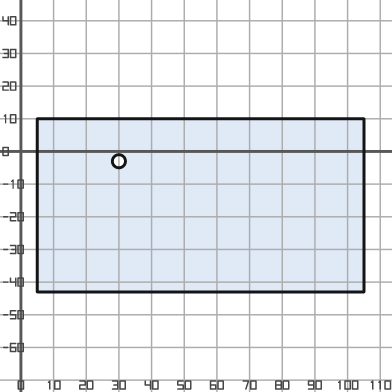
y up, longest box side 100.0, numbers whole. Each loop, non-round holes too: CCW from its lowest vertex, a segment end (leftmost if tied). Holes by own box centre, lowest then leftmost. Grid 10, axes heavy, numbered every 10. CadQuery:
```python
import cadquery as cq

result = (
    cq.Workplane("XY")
    .moveTo(5.0, -43.0)
    .lineTo(105.0, -43.0)
    .lineTo(105.0, 10.0)
    .lineTo(5.0, 10.0)
    .close()
    .moveTo(30.0, -3.0)
    .circle(2.0)
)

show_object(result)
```